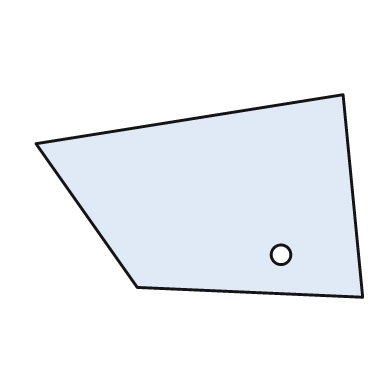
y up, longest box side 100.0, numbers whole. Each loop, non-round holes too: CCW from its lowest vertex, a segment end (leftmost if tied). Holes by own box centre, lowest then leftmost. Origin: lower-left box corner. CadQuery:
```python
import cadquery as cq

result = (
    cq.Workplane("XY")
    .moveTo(100.0, 0.0)
    .lineTo(94.0, 62.0)
    .lineTo(0.0, 47.0)
    .lineTo(31.0, 3.0)
    .close()
    .moveTo(75.0, 13.0)
    .circle(3.0)
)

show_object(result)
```